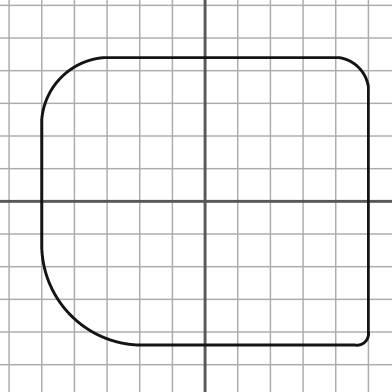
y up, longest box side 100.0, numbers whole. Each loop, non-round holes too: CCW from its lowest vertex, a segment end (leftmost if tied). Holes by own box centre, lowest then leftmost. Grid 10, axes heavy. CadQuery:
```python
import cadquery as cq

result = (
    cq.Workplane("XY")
    .moveTo(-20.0, -44.0)
    .lineTo(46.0, -44.0)
    .threePointArc((49.0, -43.0), (50.0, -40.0))
    .lineTo(50.0, 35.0)
    .threePointArc((47.0, 41.0), (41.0, 44.0))
    .lineTo(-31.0, 44.0)
    .threePointArc((-44.0, 38.0), (-50.0, 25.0))
    .lineTo(-50.0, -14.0)
    .threePointArc((-41.0, -35.0), (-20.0, -44.0))
    .close()
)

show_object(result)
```